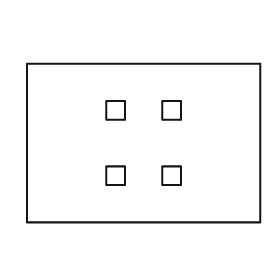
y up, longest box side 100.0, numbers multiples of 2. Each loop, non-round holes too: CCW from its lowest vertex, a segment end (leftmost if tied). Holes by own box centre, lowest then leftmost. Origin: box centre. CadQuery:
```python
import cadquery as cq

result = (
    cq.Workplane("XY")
    .moveTo(-50.0, -34.0)
    .lineTo(50.0, -34.0)
    .lineTo(50.0, 34.0)
    .lineTo(-50.0, 34.0)
    .close()
    .moveTo(-16.0, -18.0)
    .lineTo(-8.0, -18.0)
    .lineTo(-8.0, -10.0)
    .lineTo(-16.0, -10.0)
    .close()
    .moveTo(8.0, -18.0)
    .lineTo(16.0, -18.0)
    .lineTo(16.0, -10.0)
    .lineTo(8.0, -10.0)
    .close()
    .moveTo(-16.0, 10.0)
    .lineTo(-8.0, 10.0)
    .lineTo(-8.0, 18.0)
    .lineTo(-16.0, 18.0)
    .close()
    .moveTo(8.0, 10.0)
    .lineTo(16.0, 10.0)
    .lineTo(16.0, 18.0)
    .lineTo(8.0, 18.0)
    .close()
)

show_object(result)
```